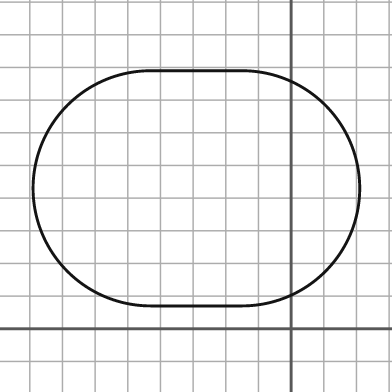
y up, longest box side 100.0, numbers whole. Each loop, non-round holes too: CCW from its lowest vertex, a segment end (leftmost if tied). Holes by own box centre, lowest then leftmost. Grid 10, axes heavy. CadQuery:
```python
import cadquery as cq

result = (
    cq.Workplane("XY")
    .moveTo(-43.0, 7.0)
    .lineTo(-15.0, 7.0)
    .threePointArc((21.0, 43.0), (-15.0, 79.0))
    .lineTo(-43.0, 79.0)
    .threePointArc((-79.0, 43.0), (-43.0, 7.0))
    .close()
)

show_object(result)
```